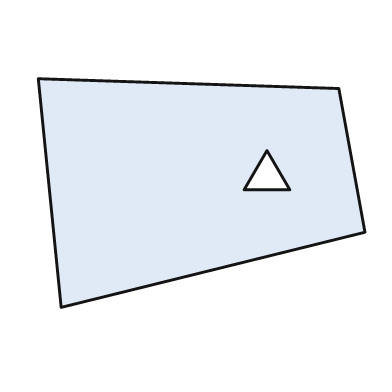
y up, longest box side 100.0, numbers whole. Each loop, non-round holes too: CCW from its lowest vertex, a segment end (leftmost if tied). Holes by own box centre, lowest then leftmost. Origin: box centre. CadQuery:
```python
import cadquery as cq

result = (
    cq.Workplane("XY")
    .moveTo(-43.0, -35.0)
    .lineTo(50.0, -12.0)
    .lineTo(42.0, 32.0)
    .lineTo(-50.0, 35.0)
    .close()
    .moveTo(13.0, 1.0)
    .lineTo(27.0, 1.0)
    .lineTo(20.0, 13.0)
    .close()
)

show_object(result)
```